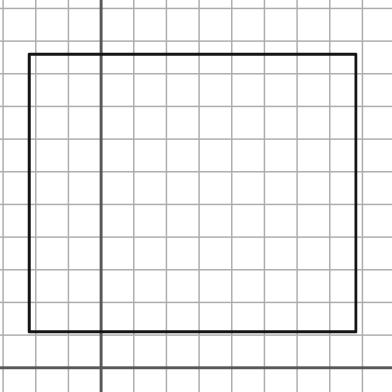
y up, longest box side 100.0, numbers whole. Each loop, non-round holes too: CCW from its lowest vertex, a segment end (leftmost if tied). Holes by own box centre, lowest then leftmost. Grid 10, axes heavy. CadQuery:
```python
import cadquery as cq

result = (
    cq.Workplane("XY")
    .moveTo(-22.0, 11.0)
    .lineTo(78.0, 11.0)
    .lineTo(78.0, 96.0)
    .lineTo(-22.0, 96.0)
    .close()
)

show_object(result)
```